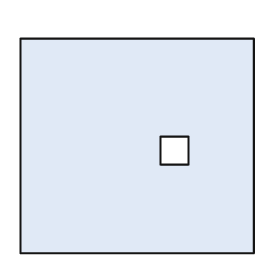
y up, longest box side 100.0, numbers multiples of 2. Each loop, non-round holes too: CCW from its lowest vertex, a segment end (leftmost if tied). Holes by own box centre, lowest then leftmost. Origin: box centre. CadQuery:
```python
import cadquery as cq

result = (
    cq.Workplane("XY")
    .moveTo(-50.0, -46.0)
    .lineTo(50.0, -46.0)
    .lineTo(50.0, 46.0)
    .lineTo(-50.0, 46.0)
    .close()
    .moveTo(10.0, -8.0)
    .lineTo(22.0, -8.0)
    .lineTo(22.0, 4.0)
    .lineTo(10.0, 4.0)
    .close()
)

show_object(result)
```